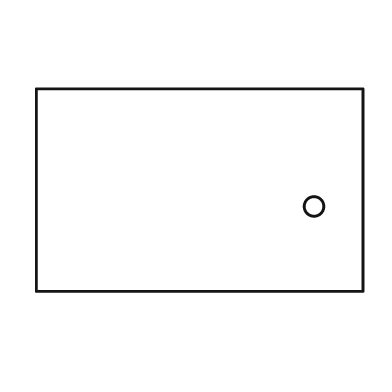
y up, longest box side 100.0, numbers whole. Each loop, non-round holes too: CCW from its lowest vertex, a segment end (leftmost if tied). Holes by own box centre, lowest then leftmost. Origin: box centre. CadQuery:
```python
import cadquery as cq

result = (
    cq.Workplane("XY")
    .moveTo(-50.0, -31.0)
    .lineTo(50.0, -31.0)
    .lineTo(50.0, 31.0)
    .lineTo(-50.0, 31.0)
    .close()
    .moveTo(35.0, -5.0)
    .circle(3.0)
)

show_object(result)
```